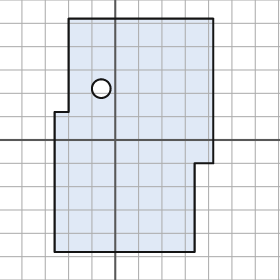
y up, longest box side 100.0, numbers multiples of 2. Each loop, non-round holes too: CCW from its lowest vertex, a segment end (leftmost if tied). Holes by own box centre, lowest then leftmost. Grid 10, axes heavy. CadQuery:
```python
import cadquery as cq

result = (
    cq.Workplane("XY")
    .moveTo(-26.0, -48.0)
    .lineTo(34.0, -48.0)
    .lineTo(34.0, -10.0)
    .lineTo(42.0, -10.0)
    .lineTo(42.0, 52.0)
    .lineTo(-20.0, 52.0)
    .lineTo(-20.0, 12.0)
    .lineTo(-26.0, 12.0)
    .close()
    .moveTo(-6.0, 22.0)
    .circle(4.0)
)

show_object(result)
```